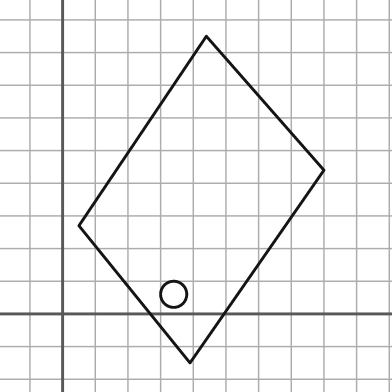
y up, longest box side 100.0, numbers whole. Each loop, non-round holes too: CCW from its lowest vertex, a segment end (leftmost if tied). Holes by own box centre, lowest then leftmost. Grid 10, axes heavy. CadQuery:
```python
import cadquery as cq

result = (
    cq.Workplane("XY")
    .moveTo(39.0, -15.0)
    .lineTo(80.0, 44.0)
    .lineTo(44.0, 85.0)
    .lineTo(5.0, 27.0)
    .close()
    .moveTo(34.0, 6.0)
    .circle(4.0)
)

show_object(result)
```